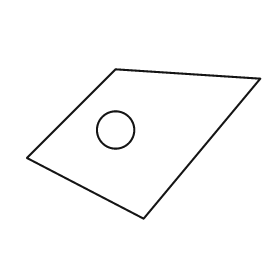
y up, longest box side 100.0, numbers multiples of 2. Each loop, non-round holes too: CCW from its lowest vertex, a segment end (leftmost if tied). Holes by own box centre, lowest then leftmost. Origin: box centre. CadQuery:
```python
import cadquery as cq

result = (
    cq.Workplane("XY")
    .moveTo(0.0, -32.0)
    .lineTo(50.0, 28.0)
    .lineTo(-12.0, 32.0)
    .lineTo(-50.0, -6.0)
    .close()
    .moveTo(-12.0, 6.0)
    .circle(8.0)
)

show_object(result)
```